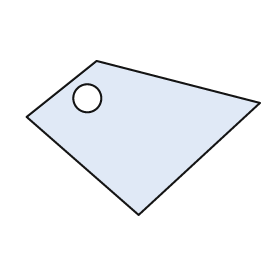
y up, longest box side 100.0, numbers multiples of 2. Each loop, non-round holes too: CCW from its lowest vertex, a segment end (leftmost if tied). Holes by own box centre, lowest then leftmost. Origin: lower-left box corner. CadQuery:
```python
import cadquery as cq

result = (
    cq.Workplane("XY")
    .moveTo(48.0, 0.0)
    .lineTo(100.0, 48.0)
    .lineTo(30.0, 66.0)
    .lineTo(0.0, 42.0)
    .close()
    .moveTo(26.0, 50.0)
    .circle(6.0)
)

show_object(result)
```